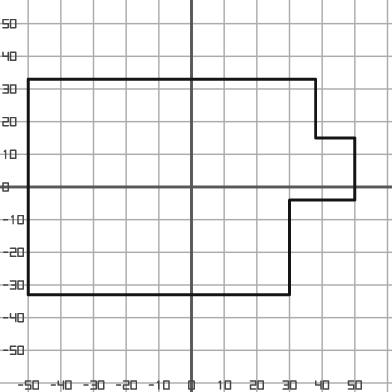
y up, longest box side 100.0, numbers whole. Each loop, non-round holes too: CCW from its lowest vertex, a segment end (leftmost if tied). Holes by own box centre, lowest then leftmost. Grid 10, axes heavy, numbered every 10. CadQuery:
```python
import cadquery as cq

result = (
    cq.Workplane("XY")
    .moveTo(-50.0, -33.0)
    .lineTo(30.0, -33.0)
    .lineTo(30.0, -4.0)
    .lineTo(50.0, -4.0)
    .lineTo(50.0, 15.0)
    .lineTo(38.0, 15.0)
    .lineTo(38.0, 33.0)
    .lineTo(-50.0, 33.0)
    .close()
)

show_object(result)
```